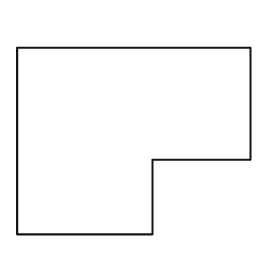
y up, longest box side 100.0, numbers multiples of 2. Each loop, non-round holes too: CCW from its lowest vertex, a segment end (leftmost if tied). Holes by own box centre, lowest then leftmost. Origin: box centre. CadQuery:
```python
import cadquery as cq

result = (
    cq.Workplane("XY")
    .moveTo(-50.0, -40.0)
    .lineTo(8.0, -40.0)
    .lineTo(8.0, -8.0)
    .lineTo(50.0, -8.0)
    .lineTo(50.0, 40.0)
    .lineTo(-50.0, 40.0)
    .close()
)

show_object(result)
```